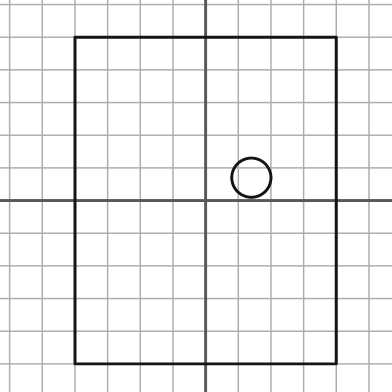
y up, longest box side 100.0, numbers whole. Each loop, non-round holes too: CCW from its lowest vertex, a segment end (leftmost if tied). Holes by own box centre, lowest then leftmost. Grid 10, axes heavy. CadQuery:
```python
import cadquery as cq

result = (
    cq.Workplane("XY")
    .moveTo(-40.0, -50.0)
    .lineTo(40.0, -50.0)
    .lineTo(40.0, 50.0)
    .lineTo(-40.0, 50.0)
    .close()
    .moveTo(14.0, 7.0)
    .circle(6.0)
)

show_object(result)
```